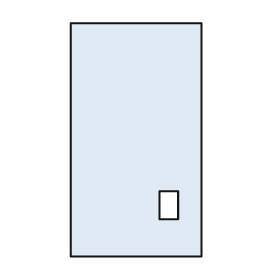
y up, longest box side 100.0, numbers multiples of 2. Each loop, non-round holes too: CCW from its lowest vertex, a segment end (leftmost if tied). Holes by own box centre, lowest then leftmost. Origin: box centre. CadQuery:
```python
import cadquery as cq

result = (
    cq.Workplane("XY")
    .moveTo(-28.0, -50.0)
    .lineTo(28.0, -50.0)
    .lineTo(28.0, 50.0)
    .lineTo(-28.0, 50.0)
    .close()
    .moveTo(10.0, -34.0)
    .lineTo(18.0, -34.0)
    .lineTo(18.0, -22.0)
    .lineTo(10.0, -22.0)
    .close()
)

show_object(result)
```